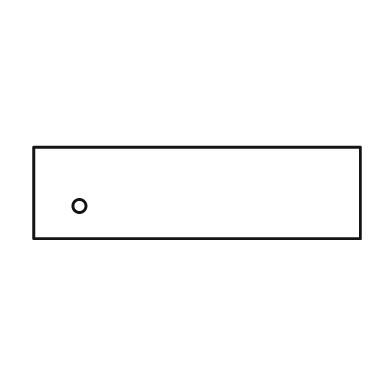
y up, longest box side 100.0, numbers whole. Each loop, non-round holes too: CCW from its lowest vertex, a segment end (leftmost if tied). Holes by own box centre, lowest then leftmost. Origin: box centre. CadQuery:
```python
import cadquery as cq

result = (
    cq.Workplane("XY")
    .moveTo(-50.0, -14.0)
    .lineTo(50.0, -14.0)
    .lineTo(50.0, 14.0)
    .lineTo(-50.0, 14.0)
    .close()
    .moveTo(-36.0, -4.0)
    .circle(2.0)
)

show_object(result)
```